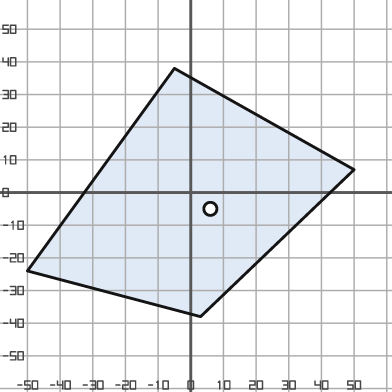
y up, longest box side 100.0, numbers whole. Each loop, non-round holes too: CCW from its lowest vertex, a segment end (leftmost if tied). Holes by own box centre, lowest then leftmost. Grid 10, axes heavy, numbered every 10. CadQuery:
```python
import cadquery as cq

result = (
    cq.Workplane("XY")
    .moveTo(3.0, -38.0)
    .lineTo(50.0, 7.0)
    .lineTo(-5.0, 38.0)
    .lineTo(-50.0, -24.0)
    .close()
    .moveTo(6.0, -5.0)
    .circle(2.0)
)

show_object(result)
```